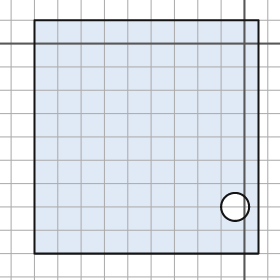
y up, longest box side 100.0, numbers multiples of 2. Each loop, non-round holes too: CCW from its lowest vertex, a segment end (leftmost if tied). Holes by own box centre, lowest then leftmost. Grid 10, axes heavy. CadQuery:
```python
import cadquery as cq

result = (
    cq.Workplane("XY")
    .moveTo(-90.0, -90.0)
    .lineTo(6.0, -90.0)
    .lineTo(6.0, 10.0)
    .lineTo(-90.0, 10.0)
    .close()
    .moveTo(-4.0, -70.0)
    .circle(6.0)
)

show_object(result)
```